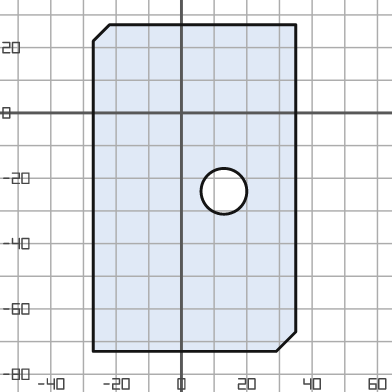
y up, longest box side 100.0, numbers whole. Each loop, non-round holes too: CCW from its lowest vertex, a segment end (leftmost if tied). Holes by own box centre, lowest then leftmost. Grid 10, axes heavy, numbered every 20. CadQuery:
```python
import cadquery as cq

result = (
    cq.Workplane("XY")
    .moveTo(-27.0, -73.0)
    .lineTo(29.0, -73.0)
    .lineTo(35.0, -67.0)
    .lineTo(35.0, 27.0)
    .lineTo(-22.0, 27.0)
    .lineTo(-27.0, 22.0)
    .close()
    .moveTo(13.0, -24.0)
    .circle(7.0)
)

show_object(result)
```